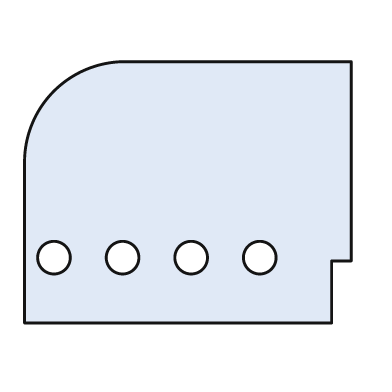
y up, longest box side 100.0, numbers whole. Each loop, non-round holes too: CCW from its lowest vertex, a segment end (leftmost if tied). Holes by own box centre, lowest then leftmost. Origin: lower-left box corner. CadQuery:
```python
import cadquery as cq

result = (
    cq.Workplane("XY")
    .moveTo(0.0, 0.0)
    .lineTo(94.0, 0.0)
    .lineTo(94.0, 19.0)
    .lineTo(100.0, 19.0)
    .lineTo(100.0, 80.0)
    .lineTo(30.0, 80.0)
    .threePointArc((9.0, 71.0), (0.0, 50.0))
    .close()
    .moveTo(9.0, 20.0)
    .circle(5.0)
    .moveTo(30.0, 20.0)
    .circle(5.0)
    .moveTo(51.0, 20.0)
    .circle(5.0)
    .moveTo(72.0, 20.0)
    .circle(5.0)
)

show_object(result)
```